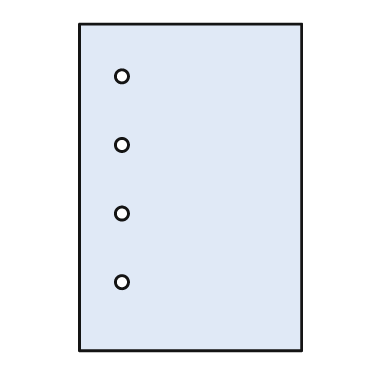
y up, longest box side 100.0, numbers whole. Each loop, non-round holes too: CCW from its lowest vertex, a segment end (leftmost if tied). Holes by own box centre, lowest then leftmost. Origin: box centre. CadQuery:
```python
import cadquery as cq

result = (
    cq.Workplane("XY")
    .moveTo(-34.0, -50.0)
    .lineTo(34.0, -50.0)
    .lineTo(34.0, 50.0)
    .lineTo(-34.0, 50.0)
    .close()
    .moveTo(-21.0, -29.0)
    .circle(2.0)
    .moveTo(-21.0, -8.0)
    .circle(2.0)
    .moveTo(-21.0, 13.0)
    .circle(2.0)
    .moveTo(-21.0, 34.0)
    .circle(2.0)
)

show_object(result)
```